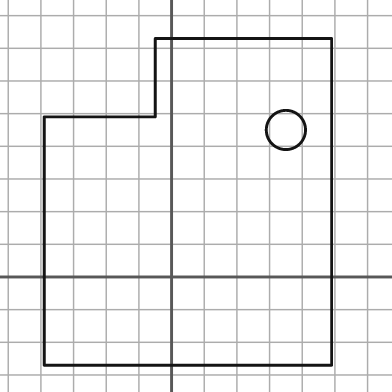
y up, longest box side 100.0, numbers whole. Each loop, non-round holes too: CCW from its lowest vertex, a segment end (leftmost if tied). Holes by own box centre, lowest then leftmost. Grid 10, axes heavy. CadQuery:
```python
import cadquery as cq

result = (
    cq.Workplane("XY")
    .moveTo(-39.0, -27.0)
    .lineTo(49.0, -27.0)
    .lineTo(49.0, 73.0)
    .lineTo(-5.0, 73.0)
    .lineTo(-5.0, 49.0)
    .lineTo(-39.0, 49.0)
    .close()
    .moveTo(35.0, 45.0)
    .circle(6.0)
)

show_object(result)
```